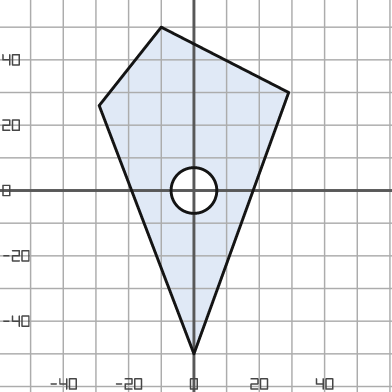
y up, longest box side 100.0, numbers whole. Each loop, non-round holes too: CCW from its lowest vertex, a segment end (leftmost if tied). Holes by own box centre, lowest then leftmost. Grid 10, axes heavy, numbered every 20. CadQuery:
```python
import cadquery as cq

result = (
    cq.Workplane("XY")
    .moveTo(0.0, -50.0)
    .lineTo(29.0, 30.0)
    .lineTo(-10.0, 50.0)
    .lineTo(-29.0, 26.0)
    .close()
    .moveTo(0.0, 0.0)
    .circle(7.0)
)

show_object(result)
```